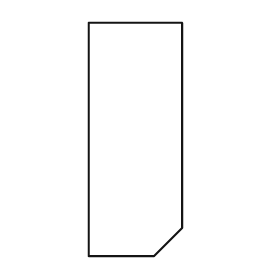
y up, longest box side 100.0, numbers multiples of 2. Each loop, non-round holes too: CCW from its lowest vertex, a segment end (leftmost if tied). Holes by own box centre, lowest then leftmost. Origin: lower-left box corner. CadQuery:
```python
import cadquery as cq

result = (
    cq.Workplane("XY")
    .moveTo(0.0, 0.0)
    .lineTo(28.0, 0.0)
    .lineTo(40.0, 12.0)
    .lineTo(40.0, 100.0)
    .lineTo(0.0, 100.0)
    .close()
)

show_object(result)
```